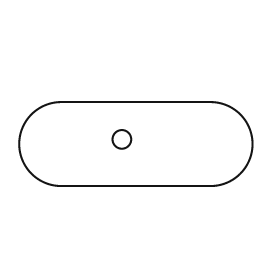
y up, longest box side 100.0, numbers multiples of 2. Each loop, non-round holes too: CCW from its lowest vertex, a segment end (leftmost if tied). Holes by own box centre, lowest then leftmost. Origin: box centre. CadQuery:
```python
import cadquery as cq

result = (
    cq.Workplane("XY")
    .moveTo(-32.0, -18.0)
    .lineTo(32.0, -18.0)
    .threePointArc((50.0, 0.0), (32.0, 18.0))
    .lineTo(-32.0, 18.0)
    .threePointArc((-50.0, 0.0), (-32.0, -18.0))
    .close()
    .moveTo(-6.0, 2.0)
    .circle(4.0)
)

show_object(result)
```